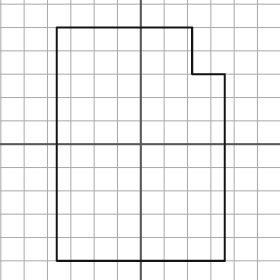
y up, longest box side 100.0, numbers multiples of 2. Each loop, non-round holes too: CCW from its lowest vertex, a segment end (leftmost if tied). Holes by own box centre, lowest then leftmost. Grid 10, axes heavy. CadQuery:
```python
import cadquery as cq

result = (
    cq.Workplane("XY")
    .moveTo(-36.0, -50.0)
    .lineTo(36.0, -50.0)
    .lineTo(36.0, 30.0)
    .lineTo(22.0, 30.0)
    .lineTo(22.0, 50.0)
    .lineTo(-36.0, 50.0)
    .close()
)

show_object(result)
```